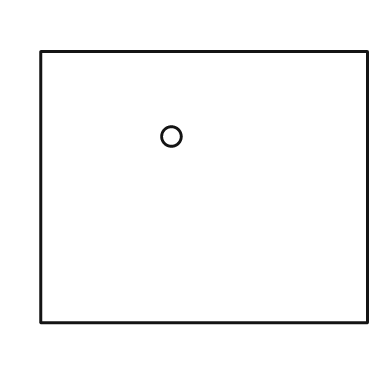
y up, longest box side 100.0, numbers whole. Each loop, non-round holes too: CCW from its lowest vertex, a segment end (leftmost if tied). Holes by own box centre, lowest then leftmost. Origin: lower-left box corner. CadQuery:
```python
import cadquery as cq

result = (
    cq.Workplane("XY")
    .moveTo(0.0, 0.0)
    .lineTo(100.0, 0.0)
    .lineTo(100.0, 83.0)
    .lineTo(0.0, 83.0)
    .close()
    .moveTo(40.0, 57.0)
    .circle(3.0)
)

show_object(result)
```